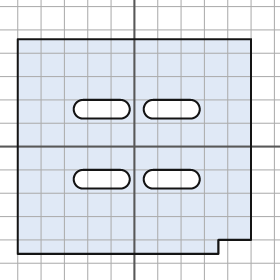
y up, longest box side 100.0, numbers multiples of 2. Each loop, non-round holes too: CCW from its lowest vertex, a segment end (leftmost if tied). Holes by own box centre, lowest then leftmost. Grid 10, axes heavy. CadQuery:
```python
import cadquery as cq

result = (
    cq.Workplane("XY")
    .moveTo(-50.0, -46.0)
    .lineTo(36.0, -46.0)
    .lineTo(36.0, -40.0)
    .lineTo(50.0, -40.0)
    .lineTo(50.0, 46.0)
    .lineTo(-50.0, 46.0)
    .close()
    .moveTo(-22.0, -18.0)
    .lineTo(-6.0, -18.0)
    .threePointArc((-2.0, -14.0), (-6.0, -10.0))
    .lineTo(-22.0, -10.0)
    .threePointArc((-26.0, -14.0), (-22.0, -18.0))
    .close()
    .moveTo(8.0, -18.0)
    .lineTo(24.0, -18.0)
    .threePointArc((28.0, -14.0), (24.0, -10.0))
    .lineTo(8.0, -10.0)
    .threePointArc((4.0, -14.0), (8.0, -18.0))
    .close()
    .moveTo(-22.0, 12.0)
    .lineTo(-6.0, 12.0)
    .threePointArc((-2.0, 16.0), (-6.0, 20.0))
    .lineTo(-22.0, 20.0)
    .threePointArc((-26.0, 16.0), (-22.0, 12.0))
    .close()
    .moveTo(8.0, 12.0)
    .lineTo(24.0, 12.0)
    .threePointArc((28.0, 16.0), (24.0, 20.0))
    .lineTo(8.0, 20.0)
    .threePointArc((4.0, 16.0), (8.0, 12.0))
    .close()
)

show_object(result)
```